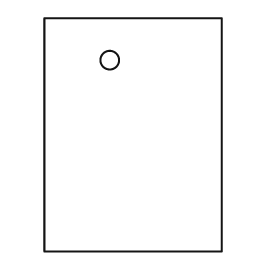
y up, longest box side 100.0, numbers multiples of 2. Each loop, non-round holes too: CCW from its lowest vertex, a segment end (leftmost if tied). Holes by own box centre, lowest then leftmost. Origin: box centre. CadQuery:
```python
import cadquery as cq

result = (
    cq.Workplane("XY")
    .moveTo(-38.0, -50.0)
    .lineTo(38.0, -50.0)
    .lineTo(38.0, 50.0)
    .lineTo(-38.0, 50.0)
    .close()
    .moveTo(-10.0, 32.0)
    .circle(4.0)
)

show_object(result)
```